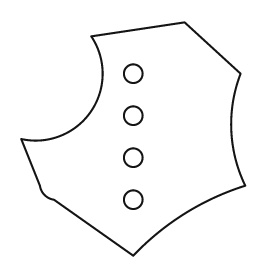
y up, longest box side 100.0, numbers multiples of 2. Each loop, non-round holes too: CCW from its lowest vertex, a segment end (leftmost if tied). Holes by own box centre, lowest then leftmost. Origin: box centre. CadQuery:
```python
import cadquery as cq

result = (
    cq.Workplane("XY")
    .moveTo(0.0, -50.0)
    .threePointArc((22.0, -32.0), (48.0, -20.0))
    .threePointArc((42.0, 4.0), (46.0, 28.0))
    .lineTo(22.0, 50.0)
    .lineTo(-18.0, 44.0)
    .threePointArc((-18.0, 12.0), (-48.0, 0.0))
    .lineTo(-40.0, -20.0)
    .threePointArc((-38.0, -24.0), (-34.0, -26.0))
    .close()
    .moveTo(0.0, -26.0)
    .circle(4.0)
    .moveTo(0.0, -8.0)
    .circle(4.0)
    .moveTo(0.0, 10.0)
    .circle(4.0)
    .moveTo(0.0, 28.0)
    .circle(4.0)
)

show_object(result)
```